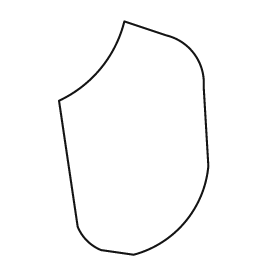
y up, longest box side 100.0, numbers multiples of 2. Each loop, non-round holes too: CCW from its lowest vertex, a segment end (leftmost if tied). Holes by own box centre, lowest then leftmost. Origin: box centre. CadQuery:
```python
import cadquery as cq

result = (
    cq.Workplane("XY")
    .moveTo(0.0, -50.0)
    .threePointArc((22.0, -36.0), (32.0, -12.0))
    .lineTo(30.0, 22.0)
    .threePointArc((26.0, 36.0), (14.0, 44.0))
    .lineTo(-4.0, 50.0)
    .threePointArc((-14.0, 30.0), (-32.0, 16.0))
    .lineTo(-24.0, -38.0)
    .threePointArc((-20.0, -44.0), (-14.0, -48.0))
    .close()
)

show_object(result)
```